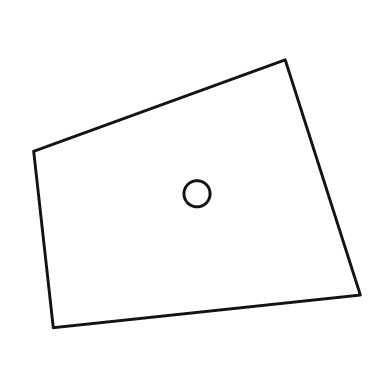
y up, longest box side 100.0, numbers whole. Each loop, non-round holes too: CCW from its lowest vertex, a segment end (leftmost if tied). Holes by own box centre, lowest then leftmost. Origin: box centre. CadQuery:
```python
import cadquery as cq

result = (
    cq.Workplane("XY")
    .moveTo(-44.0, -41.0)
    .lineTo(50.0, -31.0)
    .lineTo(27.0, 41.0)
    .lineTo(-50.0, 13.0)
    .close()
    .moveTo(0.0, 0.0)
    .circle(4.0)
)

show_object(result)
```